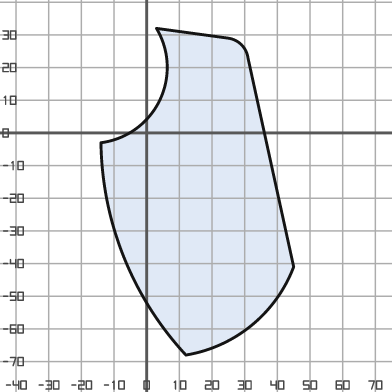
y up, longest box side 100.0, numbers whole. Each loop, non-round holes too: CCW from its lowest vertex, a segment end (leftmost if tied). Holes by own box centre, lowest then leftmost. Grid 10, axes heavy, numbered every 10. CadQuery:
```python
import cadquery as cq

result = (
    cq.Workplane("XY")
    .moveTo(12.0, -68.0)
    .threePointArc((32.0, -59.0), (45.0, -41.0))
    .lineTo(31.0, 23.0)
    .threePointArc((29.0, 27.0), (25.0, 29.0))
    .lineTo(3.0, 32.0)
    .threePointArc((4.0, 10.0), (-14.0, -3.0))
    .threePointArc((-7.0, -38.0), (12.0, -68.0))
    .close()
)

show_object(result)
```